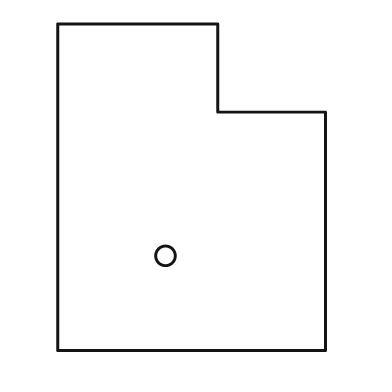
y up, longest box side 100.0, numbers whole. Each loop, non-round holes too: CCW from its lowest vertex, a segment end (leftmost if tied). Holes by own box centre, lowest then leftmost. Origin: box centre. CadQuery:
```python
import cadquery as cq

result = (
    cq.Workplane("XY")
    .moveTo(-41.0, -50.0)
    .lineTo(41.0, -50.0)
    .lineTo(41.0, 23.0)
    .lineTo(8.0, 23.0)
    .lineTo(8.0, 50.0)
    .lineTo(-41.0, 50.0)
    .close()
    .moveTo(-8.0, -21.0)
    .circle(3.0)
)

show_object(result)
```